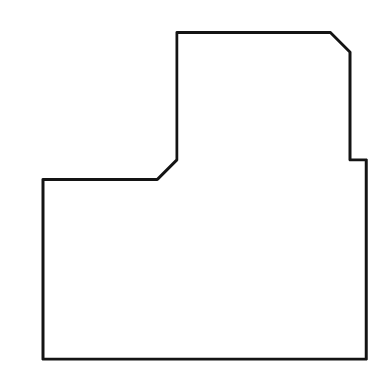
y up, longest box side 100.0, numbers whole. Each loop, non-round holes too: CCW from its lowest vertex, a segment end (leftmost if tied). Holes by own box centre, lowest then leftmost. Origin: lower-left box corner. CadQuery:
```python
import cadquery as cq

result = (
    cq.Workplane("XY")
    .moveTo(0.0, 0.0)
    .lineTo(99.0, 0.0)
    .lineTo(99.0, 61.0)
    .lineTo(94.0, 61.0)
    .lineTo(94.0, 94.0)
    .lineTo(88.0, 100.0)
    .lineTo(41.0, 100.0)
    .lineTo(41.0, 61.0)
    .lineTo(35.0, 55.0)
    .lineTo(0.0, 55.0)
    .close()
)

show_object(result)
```